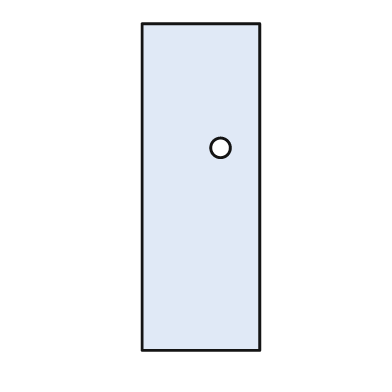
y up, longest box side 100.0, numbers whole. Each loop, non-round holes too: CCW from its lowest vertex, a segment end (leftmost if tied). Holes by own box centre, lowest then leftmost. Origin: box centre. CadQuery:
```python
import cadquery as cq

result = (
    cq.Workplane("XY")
    .moveTo(-18.0, -50.0)
    .lineTo(18.0, -50.0)
    .lineTo(18.0, 50.0)
    .lineTo(-18.0, 50.0)
    .close()
    .moveTo(6.0, 12.0)
    .circle(3.0)
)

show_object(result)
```